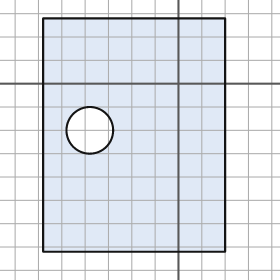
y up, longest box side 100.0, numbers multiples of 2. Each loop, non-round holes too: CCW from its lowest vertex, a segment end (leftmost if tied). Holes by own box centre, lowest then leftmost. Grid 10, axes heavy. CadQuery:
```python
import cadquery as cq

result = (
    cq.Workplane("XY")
    .moveTo(-58.0, -72.0)
    .lineTo(20.0, -72.0)
    .lineTo(20.0, 28.0)
    .lineTo(-58.0, 28.0)
    .close()
    .moveTo(-38.0, -20.0)
    .circle(10.0)
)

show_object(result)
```